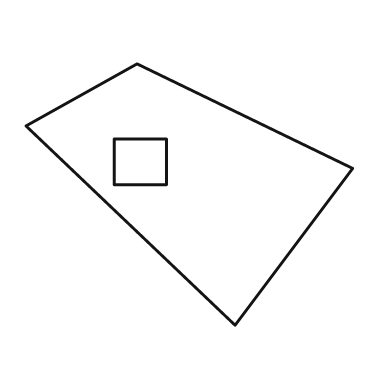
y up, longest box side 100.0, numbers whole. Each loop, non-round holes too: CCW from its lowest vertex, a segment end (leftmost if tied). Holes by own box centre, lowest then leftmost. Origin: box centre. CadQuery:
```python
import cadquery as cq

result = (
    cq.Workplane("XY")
    .moveTo(14.0, -40.0)
    .lineTo(50.0, 8.0)
    .lineTo(-16.0, 40.0)
    .lineTo(-50.0, 21.0)
    .close()
    .moveTo(-23.0, 3.0)
    .lineTo(-7.0, 3.0)
    .lineTo(-7.0, 17.0)
    .lineTo(-23.0, 17.0)
    .close()
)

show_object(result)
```